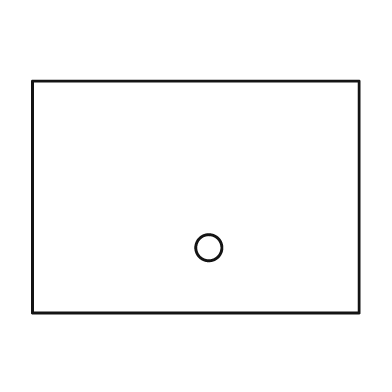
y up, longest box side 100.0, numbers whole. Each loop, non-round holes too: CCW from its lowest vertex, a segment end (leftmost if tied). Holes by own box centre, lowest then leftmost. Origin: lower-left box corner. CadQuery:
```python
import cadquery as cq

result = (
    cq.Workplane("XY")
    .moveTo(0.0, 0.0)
    .lineTo(100.0, 0.0)
    .lineTo(100.0, 71.0)
    .lineTo(0.0, 71.0)
    .close()
    .moveTo(54.0, 20.0)
    .circle(4.0)
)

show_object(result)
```